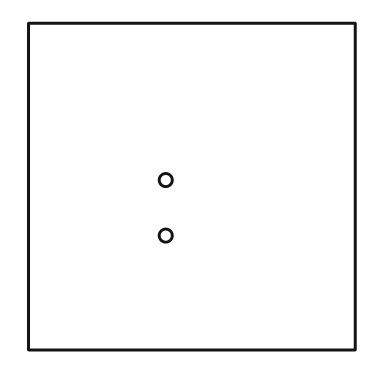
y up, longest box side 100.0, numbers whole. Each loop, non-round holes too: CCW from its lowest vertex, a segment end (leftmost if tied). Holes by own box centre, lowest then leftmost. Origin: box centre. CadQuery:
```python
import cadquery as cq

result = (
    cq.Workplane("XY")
    .moveTo(-50.0, -50.0)
    .lineTo(50.0, -50.0)
    .lineTo(50.0, 50.0)
    .lineTo(-50.0, 50.0)
    .close()
    .moveTo(-8.0, -15.0)
    .circle(2.0)
    .moveTo(-8.0, 2.0)
    .circle(2.0)
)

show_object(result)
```